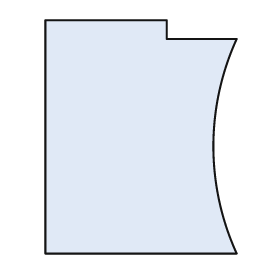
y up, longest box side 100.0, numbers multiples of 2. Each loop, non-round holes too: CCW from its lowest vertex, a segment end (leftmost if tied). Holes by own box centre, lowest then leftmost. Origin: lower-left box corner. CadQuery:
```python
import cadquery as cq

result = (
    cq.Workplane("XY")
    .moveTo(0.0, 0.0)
    .lineTo(82.0, 0.0)
    .threePointArc((72.0, 46.0), (82.0, 92.0))
    .lineTo(52.0, 92.0)
    .lineTo(52.0, 100.0)
    .lineTo(0.0, 100.0)
    .close()
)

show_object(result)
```